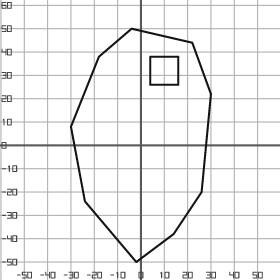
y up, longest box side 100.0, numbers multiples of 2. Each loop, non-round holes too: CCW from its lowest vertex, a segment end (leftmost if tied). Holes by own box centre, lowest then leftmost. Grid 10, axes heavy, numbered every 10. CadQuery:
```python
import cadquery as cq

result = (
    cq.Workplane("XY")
    .moveTo(-2.0, -50.0)
    .lineTo(14.0, -38.0)
    .lineTo(26.0, -20.0)
    .lineTo(30.0, 22.0)
    .lineTo(22.0, 44.0)
    .lineTo(-4.0, 50.0)
    .lineTo(-18.0, 38.0)
    .lineTo(-30.0, 8.0)
    .lineTo(-24.0, -24.0)
    .close()
    .moveTo(4.0, 26.0)
    .lineTo(16.0, 26.0)
    .lineTo(16.0, 38.0)
    .lineTo(4.0, 38.0)
    .close()
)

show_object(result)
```